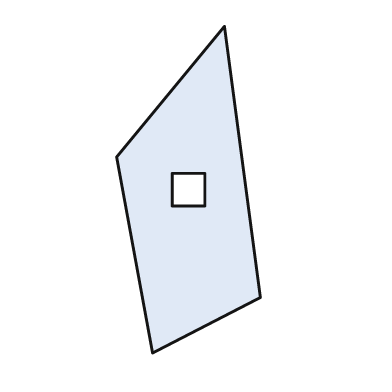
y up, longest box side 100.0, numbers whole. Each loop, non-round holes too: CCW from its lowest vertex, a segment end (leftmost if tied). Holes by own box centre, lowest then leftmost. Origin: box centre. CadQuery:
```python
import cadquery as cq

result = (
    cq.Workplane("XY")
    .moveTo(-11.0, -50.0)
    .lineTo(22.0, -33.0)
    .lineTo(11.0, 50.0)
    .lineTo(-22.0, 10.0)
    .close()
    .moveTo(-5.0, -5.0)
    .lineTo(5.0, -5.0)
    .lineTo(5.0, 5.0)
    .lineTo(-5.0, 5.0)
    .close()
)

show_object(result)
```